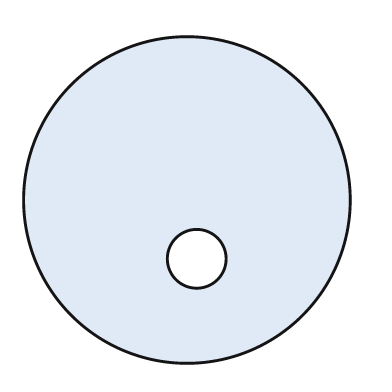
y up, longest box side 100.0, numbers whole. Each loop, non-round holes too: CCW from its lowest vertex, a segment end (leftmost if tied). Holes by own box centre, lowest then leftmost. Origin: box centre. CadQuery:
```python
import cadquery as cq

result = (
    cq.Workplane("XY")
    .moveTo(0.0, 0.0)
    .circle(50.0)
    .moveTo(3.0, -18.0)
    .circle(9.0)
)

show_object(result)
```